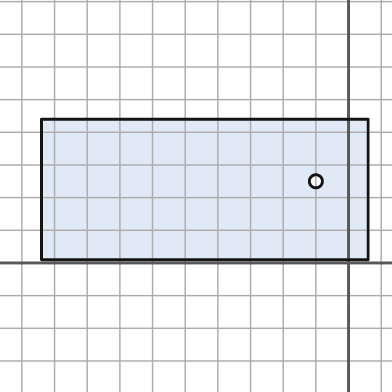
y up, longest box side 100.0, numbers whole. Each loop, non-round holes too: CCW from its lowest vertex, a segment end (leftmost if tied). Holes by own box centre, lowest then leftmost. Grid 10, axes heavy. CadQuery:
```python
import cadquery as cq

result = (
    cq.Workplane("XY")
    .moveTo(-94.0, 1.0)
    .lineTo(6.0, 1.0)
    .lineTo(6.0, 44.0)
    .lineTo(-94.0, 44.0)
    .close()
    .moveTo(-10.0, 25.0)
    .circle(2.0)
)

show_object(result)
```